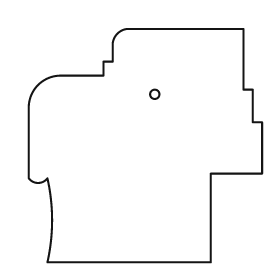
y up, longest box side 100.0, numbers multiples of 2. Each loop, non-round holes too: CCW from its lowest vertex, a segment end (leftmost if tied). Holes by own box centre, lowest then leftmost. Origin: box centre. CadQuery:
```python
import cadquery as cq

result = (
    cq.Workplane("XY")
    .moveTo(-42.0, -50.0)
    .lineTo(28.0, -50.0)
    .lineTo(28.0, -12.0)
    .lineTo(50.0, -12.0)
    .lineTo(50.0, 10.0)
    .lineTo(46.0, 10.0)
    .lineTo(46.0, 24.0)
    .lineTo(42.0, 24.0)
    .lineTo(42.0, 50.0)
    .lineTo(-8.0, 50.0)
    .threePointArc((-12.0, 48.0), (-14.0, 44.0))
    .lineTo(-14.0, 36.0)
    .lineTo(-18.0, 36.0)
    .lineTo(-18.0, 30.0)
    .lineTo(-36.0, 30.0)
    .threePointArc((-46.0, 26.0), (-50.0, 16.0))
    .lineTo(-50.0, -14.0)
    .threePointArc((-46.0, -16.0), (-42.0, -14.0))
    .threePointArc((-40.0, -32.0), (-42.0, -50.0))
    .close()
    .moveTo(4.0, 22.0)
    .circle(2.0)
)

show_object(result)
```